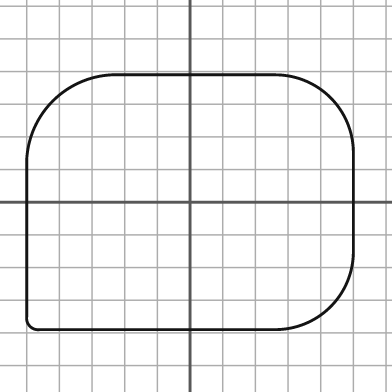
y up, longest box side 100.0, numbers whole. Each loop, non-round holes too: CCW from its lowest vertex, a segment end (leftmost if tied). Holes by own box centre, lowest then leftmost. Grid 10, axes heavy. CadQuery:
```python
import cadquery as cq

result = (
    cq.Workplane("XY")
    .moveTo(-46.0, -39.0)
    .lineTo(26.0, -39.0)
    .threePointArc((43.0, -32.0), (50.0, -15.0))
    .lineTo(50.0, 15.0)
    .threePointArc((43.0, 32.0), (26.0, 39.0))
    .lineTo(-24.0, 39.0)
    .threePointArc((-42.0, 31.0), (-50.0, 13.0))
    .lineTo(-50.0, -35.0)
    .threePointArc((-49.0, -38.0), (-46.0, -39.0))
    .close()
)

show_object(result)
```